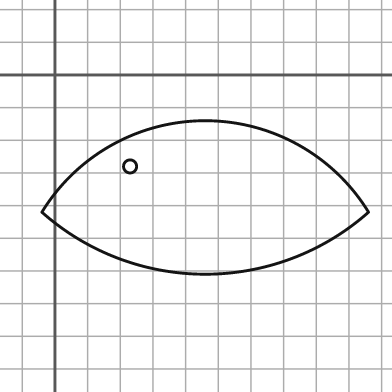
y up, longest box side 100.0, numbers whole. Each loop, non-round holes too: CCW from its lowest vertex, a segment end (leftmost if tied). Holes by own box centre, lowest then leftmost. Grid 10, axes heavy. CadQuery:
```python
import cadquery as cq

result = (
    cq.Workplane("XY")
    .moveTo(-4.0, -42.0)
    .threePointArc((46.0, -61.0), (96.0, -42.0))
    .threePointArc((46.0, -14.0), (-4.0, -42.0))
    .close()
    .moveTo(23.0, -28.0)
    .circle(2.0)
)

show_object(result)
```